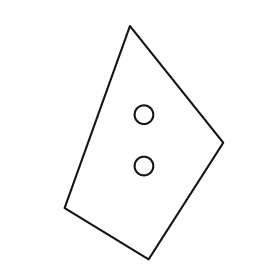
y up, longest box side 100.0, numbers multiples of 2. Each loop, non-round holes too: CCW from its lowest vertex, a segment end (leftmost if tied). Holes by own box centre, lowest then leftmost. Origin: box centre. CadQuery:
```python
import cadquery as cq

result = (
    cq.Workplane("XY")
    .moveTo(2.0, -50.0)
    .lineTo(34.0, 0.0)
    .lineTo(-6.0, 50.0)
    .lineTo(-34.0, -28.0)
    .close()
    .moveTo(0.0, -10.0)
    .circle(4.0)
    .moveTo(0.0, 12.0)
    .circle(4.0)
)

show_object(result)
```